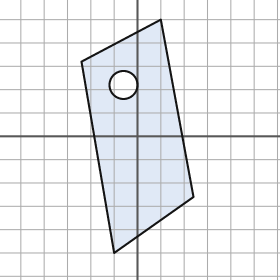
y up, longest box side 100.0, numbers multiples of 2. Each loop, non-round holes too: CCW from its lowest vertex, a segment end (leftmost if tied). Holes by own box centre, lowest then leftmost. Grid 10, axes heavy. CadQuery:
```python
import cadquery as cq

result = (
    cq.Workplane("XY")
    .moveTo(-10.0, -50.0)
    .lineTo(24.0, -26.0)
    .lineTo(10.0, 50.0)
    .lineTo(-24.0, 32.0)
    .close()
    .moveTo(-6.0, 22.0)
    .circle(6.0)
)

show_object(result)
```